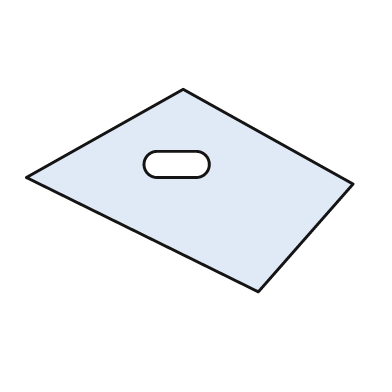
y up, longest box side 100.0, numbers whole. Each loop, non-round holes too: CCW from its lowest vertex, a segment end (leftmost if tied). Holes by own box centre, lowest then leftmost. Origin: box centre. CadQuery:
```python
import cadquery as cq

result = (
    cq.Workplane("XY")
    .moveTo(21.0, -31.0)
    .lineTo(50.0, 2.0)
    .lineTo(-2.0, 31.0)
    .lineTo(-50.0, 4.0)
    .close()
    .moveTo(-10.0, 4.0)
    .lineTo(2.0, 4.0)
    .threePointArc((6.0, 8.0), (2.0, 12.0))
    .lineTo(-10.0, 12.0)
    .threePointArc((-14.0, 8.0), (-10.0, 4.0))
    .close()
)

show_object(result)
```